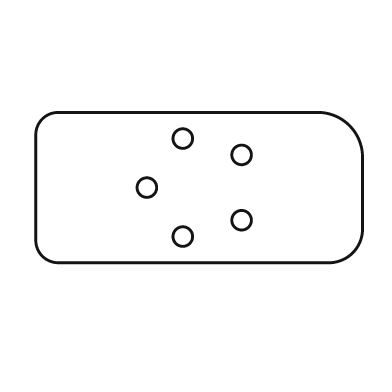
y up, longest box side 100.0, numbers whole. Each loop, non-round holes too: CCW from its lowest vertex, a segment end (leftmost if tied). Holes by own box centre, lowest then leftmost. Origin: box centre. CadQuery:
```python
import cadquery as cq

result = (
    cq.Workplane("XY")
    .moveTo(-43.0, -23.0)
    .lineTo(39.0, -23.0)
    .threePointArc((47.0, -20.0), (50.0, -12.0))
    .lineTo(50.0, 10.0)
    .threePointArc((46.0, 19.0), (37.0, 23.0))
    .lineTo(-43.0, 23.0)
    .threePointArc((-48.0, 21.0), (-50.0, 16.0))
    .lineTo(-50.0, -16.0)
    .threePointArc((-48.0, -21.0), (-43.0, -23.0))
    .close()
    .moveTo(-5.0, -15.0)
    .circle(3.0)
    .moveTo(13.0, -10.0)
    .circle(3.0)
    .moveTo(-16.0, 0.0)
    .circle(3.0)
    .moveTo(13.0, 10.0)
    .circle(3.0)
    .moveTo(-5.0, 15.0)
    .circle(3.0)
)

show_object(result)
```